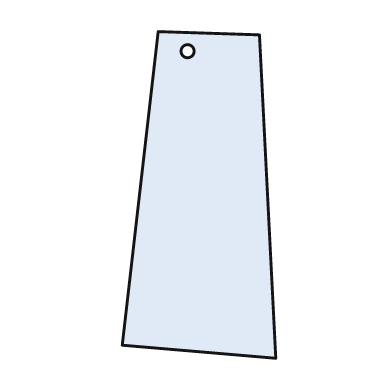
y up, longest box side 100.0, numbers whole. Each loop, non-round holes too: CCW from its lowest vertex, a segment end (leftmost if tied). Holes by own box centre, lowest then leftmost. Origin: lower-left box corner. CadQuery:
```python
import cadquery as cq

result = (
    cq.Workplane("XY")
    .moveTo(47.0, 0.0)
    .lineTo(42.0, 99.0)
    .lineTo(11.0, 100.0)
    .lineTo(0.0, 4.0)
    .close()
    .moveTo(20.0, 94.0)
    .circle(2.0)
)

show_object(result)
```